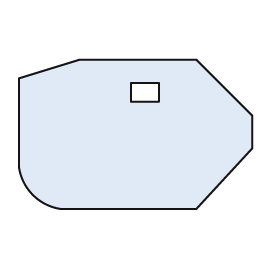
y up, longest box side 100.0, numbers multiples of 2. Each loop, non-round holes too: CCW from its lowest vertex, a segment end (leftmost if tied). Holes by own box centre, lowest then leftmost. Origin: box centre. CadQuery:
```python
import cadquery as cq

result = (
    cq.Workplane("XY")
    .moveTo(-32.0, -32.0)
    .lineTo(26.0, -32.0)
    .lineTo(50.0, -6.0)
    .lineTo(50.0, 8.0)
    .lineTo(26.0, 32.0)
    .lineTo(-24.0, 32.0)
    .lineTo(-50.0, 24.0)
    .lineTo(-50.0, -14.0)
    .threePointArc((-44.0, -26.0), (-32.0, -32.0))
    .close()
    .moveTo(-2.0, 14.0)
    .lineTo(10.0, 14.0)
    .lineTo(10.0, 22.0)
    .lineTo(-2.0, 22.0)
    .close()
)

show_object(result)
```